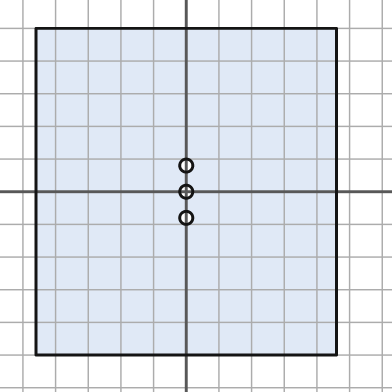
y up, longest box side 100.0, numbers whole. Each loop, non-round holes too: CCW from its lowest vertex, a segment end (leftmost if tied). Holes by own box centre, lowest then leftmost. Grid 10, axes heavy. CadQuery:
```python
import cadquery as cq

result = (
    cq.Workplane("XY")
    .moveTo(-46.0, -50.0)
    .lineTo(46.0, -50.0)
    .lineTo(46.0, 50.0)
    .lineTo(-46.0, 50.0)
    .close()
    .moveTo(0.0, -8.0)
    .circle(2.0)
    .moveTo(0.0, 0.0)
    .circle(2.0)
    .moveTo(0.0, 8.0)
    .circle(2.0)
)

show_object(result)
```